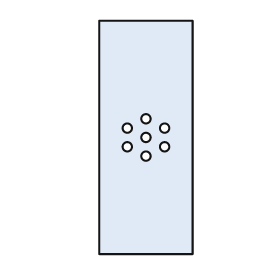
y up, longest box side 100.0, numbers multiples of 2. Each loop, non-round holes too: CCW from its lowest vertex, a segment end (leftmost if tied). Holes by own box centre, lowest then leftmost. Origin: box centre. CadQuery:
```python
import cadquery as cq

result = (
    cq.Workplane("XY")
    .moveTo(-20.0, -50.0)
    .lineTo(20.0, -50.0)
    .lineTo(20.0, 50.0)
    .lineTo(-20.0, 50.0)
    .close()
    .moveTo(0.0, -8.0)
    .circle(2.0)
    .moveTo(-8.0, -4.0)
    .circle(2.0)
    .moveTo(8.0, -4.0)
    .circle(2.0)
    .moveTo(0.0, 0.0)
    .circle(2.0)
    .moveTo(-8.0, 4.0)
    .circle(2.0)
    .moveTo(8.0, 4.0)
    .circle(2.0)
    .moveTo(0.0, 8.0)
    .circle(2.0)
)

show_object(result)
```